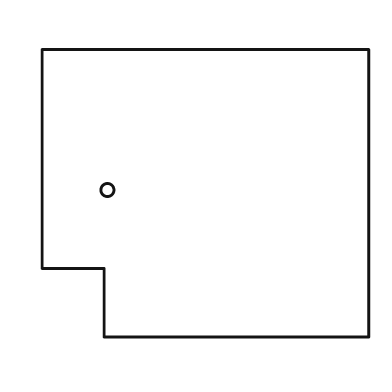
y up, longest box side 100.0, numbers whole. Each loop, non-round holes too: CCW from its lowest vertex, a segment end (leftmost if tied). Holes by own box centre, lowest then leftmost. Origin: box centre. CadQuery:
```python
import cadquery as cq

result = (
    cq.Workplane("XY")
    .moveTo(-31.0, -44.0)
    .lineTo(50.0, -44.0)
    .lineTo(50.0, 44.0)
    .lineTo(-50.0, 44.0)
    .lineTo(-50.0, -23.0)
    .lineTo(-31.0, -23.0)
    .close()
    .moveTo(-30.0, 1.0)
    .circle(2.0)
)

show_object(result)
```